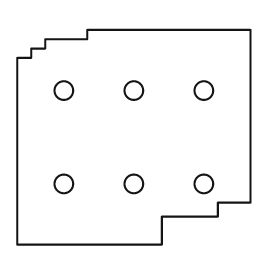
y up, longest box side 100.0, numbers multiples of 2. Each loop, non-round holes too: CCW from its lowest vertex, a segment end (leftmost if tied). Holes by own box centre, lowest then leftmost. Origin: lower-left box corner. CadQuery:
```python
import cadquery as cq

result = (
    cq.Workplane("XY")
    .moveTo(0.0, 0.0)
    .lineTo(62.0, 0.0)
    .lineTo(62.0, 12.0)
    .lineTo(86.0, 12.0)
    .lineTo(86.0, 18.0)
    .lineTo(100.0, 18.0)
    .lineTo(100.0, 92.0)
    .lineTo(30.0, 92.0)
    .lineTo(30.0, 88.0)
    .lineTo(12.0, 88.0)
    .lineTo(12.0, 84.0)
    .lineTo(6.0, 84.0)
    .lineTo(6.0, 80.0)
    .lineTo(0.0, 80.0)
    .close()
    .moveTo(20.0, 26.0)
    .circle(4.0)
    .moveTo(50.0, 26.0)
    .circle(4.0)
    .moveTo(80.0, 26.0)
    .circle(4.0)
    .moveTo(20.0, 66.0)
    .circle(4.0)
    .moveTo(50.0, 66.0)
    .circle(4.0)
    .moveTo(80.0, 66.0)
    .circle(4.0)
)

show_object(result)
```